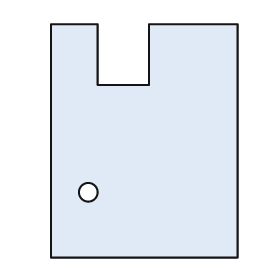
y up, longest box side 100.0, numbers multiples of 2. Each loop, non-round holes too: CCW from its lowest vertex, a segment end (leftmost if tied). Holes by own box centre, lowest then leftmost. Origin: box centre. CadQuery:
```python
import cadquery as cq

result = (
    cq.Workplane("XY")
    .moveTo(-40.0, -50.0)
    .lineTo(40.0, -50.0)
    .lineTo(40.0, 50.0)
    .lineTo(2.0, 50.0)
    .lineTo(2.0, 24.0)
    .lineTo(-20.0, 24.0)
    .lineTo(-20.0, 50.0)
    .lineTo(-40.0, 50.0)
    .close()
    .moveTo(-24.0, -22.0)
    .circle(4.0)
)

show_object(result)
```